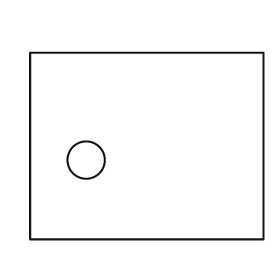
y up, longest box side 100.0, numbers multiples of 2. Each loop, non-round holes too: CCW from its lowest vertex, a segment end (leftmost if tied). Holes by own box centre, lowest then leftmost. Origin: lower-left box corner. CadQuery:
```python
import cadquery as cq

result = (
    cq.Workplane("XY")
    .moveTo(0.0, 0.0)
    .lineTo(100.0, 0.0)
    .lineTo(100.0, 80.0)
    .lineTo(0.0, 80.0)
    .close()
    .moveTo(24.0, 34.0)
    .circle(8.0)
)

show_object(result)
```